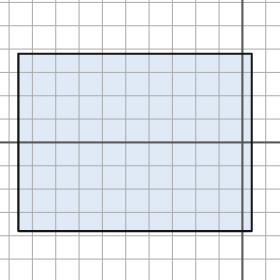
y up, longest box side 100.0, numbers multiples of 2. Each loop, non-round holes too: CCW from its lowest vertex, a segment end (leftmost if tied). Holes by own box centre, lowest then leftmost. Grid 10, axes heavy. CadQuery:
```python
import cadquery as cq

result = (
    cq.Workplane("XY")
    .moveTo(-96.0, -38.0)
    .lineTo(4.0, -38.0)
    .lineTo(4.0, 38.0)
    .lineTo(-96.0, 38.0)
    .close()
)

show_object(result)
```